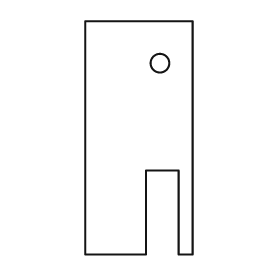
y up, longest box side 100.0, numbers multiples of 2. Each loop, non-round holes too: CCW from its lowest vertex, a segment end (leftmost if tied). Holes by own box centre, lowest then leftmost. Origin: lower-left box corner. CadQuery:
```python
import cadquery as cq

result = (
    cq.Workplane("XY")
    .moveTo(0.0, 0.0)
    .lineTo(26.0, 0.0)
    .lineTo(26.0, 36.0)
    .lineTo(40.0, 36.0)
    .lineTo(40.0, 0.0)
    .lineTo(46.0, 0.0)
    .lineTo(46.0, 100.0)
    .lineTo(0.0, 100.0)
    .close()
    .moveTo(32.0, 82.0)
    .circle(4.0)
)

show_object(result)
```